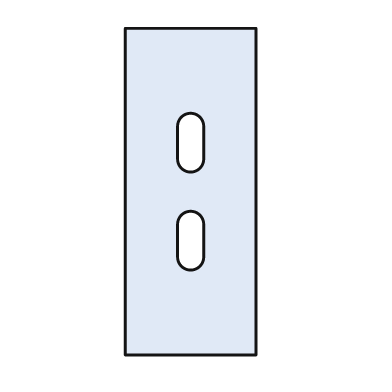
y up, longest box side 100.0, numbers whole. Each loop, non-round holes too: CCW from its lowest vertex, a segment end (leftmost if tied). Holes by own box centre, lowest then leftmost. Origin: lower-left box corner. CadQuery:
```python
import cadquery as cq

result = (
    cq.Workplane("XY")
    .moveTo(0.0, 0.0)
    .lineTo(40.0, 0.0)
    .lineTo(40.0, 100.0)
    .lineTo(0.0, 100.0)
    .close()
    .moveTo(16.0, 30.0)
    .threePointArc((20.0, 26.0), (24.0, 30.0))
    .lineTo(24.0, 40.0)
    .threePointArc((20.0, 44.0), (16.0, 40.0))
    .close()
    .moveTo(16.0, 60.0)
    .threePointArc((20.0, 56.0), (24.0, 60.0))
    .lineTo(24.0, 70.0)
    .threePointArc((20.0, 74.0), (16.0, 70.0))
    .close()
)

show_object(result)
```